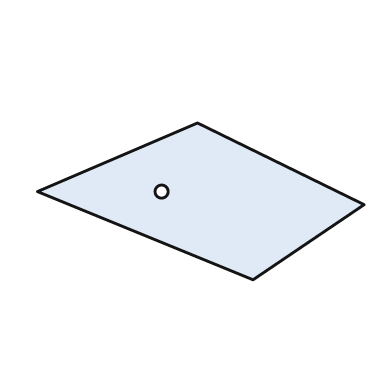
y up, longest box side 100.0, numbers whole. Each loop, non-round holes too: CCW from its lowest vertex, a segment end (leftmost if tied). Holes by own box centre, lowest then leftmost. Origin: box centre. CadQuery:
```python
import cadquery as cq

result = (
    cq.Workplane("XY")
    .moveTo(16.0, -24.0)
    .lineTo(50.0, -1.0)
    .lineTo(-1.0, 24.0)
    .lineTo(-50.0, 3.0)
    .close()
    .moveTo(-12.0, 3.0)
    .circle(2.0)
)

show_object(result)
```